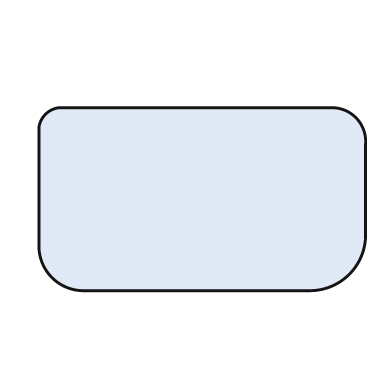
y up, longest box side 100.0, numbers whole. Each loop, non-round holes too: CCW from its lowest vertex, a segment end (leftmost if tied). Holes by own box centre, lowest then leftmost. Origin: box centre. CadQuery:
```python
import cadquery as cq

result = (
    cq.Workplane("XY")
    .moveTo(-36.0, -28.0)
    .lineTo(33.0, -28.0)
    .threePointArc((45.0, -23.0), (50.0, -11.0))
    .lineTo(50.0, 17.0)
    .threePointArc((47.0, 25.0), (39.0, 28.0))
    .lineTo(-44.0, 28.0)
    .threePointArc((-48.0, 26.0), (-50.0, 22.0))
    .lineTo(-50.0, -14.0)
    .threePointArc((-46.0, -24.0), (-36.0, -28.0))
    .close()
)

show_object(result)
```